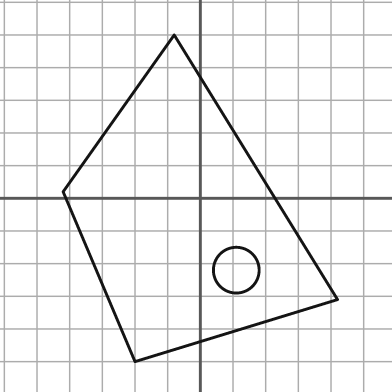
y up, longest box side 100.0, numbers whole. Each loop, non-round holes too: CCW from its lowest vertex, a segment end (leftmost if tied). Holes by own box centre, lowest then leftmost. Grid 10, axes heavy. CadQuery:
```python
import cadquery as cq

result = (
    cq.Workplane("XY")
    .moveTo(-20.0, -50.0)
    .lineTo(42.0, -31.0)
    .lineTo(-8.0, 50.0)
    .lineTo(-42.0, 2.0)
    .close()
    .moveTo(11.0, -22.0)
    .circle(7.0)
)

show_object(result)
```